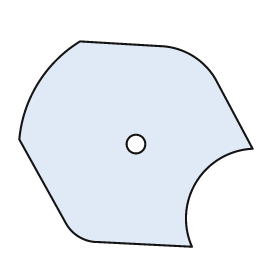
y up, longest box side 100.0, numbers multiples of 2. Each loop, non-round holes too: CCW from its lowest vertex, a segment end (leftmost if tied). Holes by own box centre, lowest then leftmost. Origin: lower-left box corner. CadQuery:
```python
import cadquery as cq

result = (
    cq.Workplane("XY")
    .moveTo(74.0, 0.0)
    .threePointArc((76.0, 28.0), (100.0, 42.0))
    .lineTo(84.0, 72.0)
    .threePointArc((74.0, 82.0), (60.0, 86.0))
    .lineTo(26.0, 88.0)
    .threePointArc((8.0, 70.0), (0.0, 46.0))
    .lineTo(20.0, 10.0)
    .threePointArc((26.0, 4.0), (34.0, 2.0))
    .close()
    .moveTo(50.0, 44.0)
    .circle(4.0)
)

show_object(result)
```